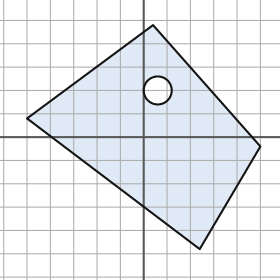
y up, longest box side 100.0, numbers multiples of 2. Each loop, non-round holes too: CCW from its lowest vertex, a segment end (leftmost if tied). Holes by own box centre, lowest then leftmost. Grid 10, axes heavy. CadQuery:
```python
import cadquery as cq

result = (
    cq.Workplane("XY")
    .moveTo(24.0, -48.0)
    .lineTo(50.0, -4.0)
    .lineTo(4.0, 48.0)
    .lineTo(-50.0, 8.0)
    .close()
    .moveTo(6.0, 20.0)
    .circle(6.0)
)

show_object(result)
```